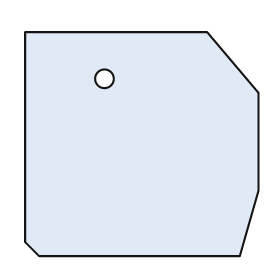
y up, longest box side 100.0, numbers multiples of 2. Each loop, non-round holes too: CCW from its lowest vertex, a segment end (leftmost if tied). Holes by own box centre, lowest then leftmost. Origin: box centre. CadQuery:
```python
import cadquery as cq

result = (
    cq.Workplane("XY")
    .moveTo(-44.0, -48.0)
    .lineTo(42.0, -48.0)
    .lineTo(50.0, -20.0)
    .lineTo(50.0, 22.0)
    .lineTo(28.0, 48.0)
    .lineTo(-50.0, 48.0)
    .lineTo(-50.0, -42.0)
    .close()
    .moveTo(-16.0, 28.0)
    .circle(4.0)
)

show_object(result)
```